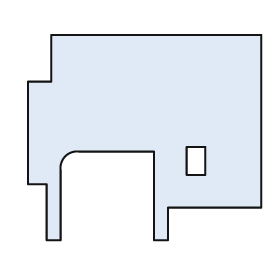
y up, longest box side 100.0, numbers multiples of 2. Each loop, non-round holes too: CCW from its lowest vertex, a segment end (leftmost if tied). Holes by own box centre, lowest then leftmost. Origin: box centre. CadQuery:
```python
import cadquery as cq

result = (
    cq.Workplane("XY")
    .moveTo(-42.0, -44.0)
    .lineTo(-36.0, -44.0)
    .lineTo(-36.0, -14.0)
    .threePointArc((-34.0, -8.0), (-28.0, -6.0))
    .lineTo(4.0, -6.0)
    .lineTo(4.0, -44.0)
    .lineTo(10.0, -44.0)
    .lineTo(10.0, -30.0)
    .lineTo(50.0, -30.0)
    .lineTo(50.0, 44.0)
    .lineTo(-40.0, 44.0)
    .lineTo(-40.0, 24.0)
    .lineTo(-50.0, 24.0)
    .lineTo(-50.0, -20.0)
    .lineTo(-42.0, -20.0)
    .close()
    .moveTo(18.0, -16.0)
    .lineTo(26.0, -16.0)
    .lineTo(26.0, -4.0)
    .lineTo(18.0, -4.0)
    .close()
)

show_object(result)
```